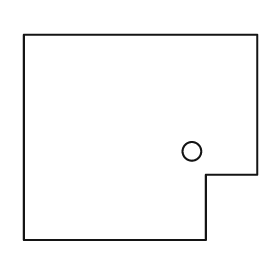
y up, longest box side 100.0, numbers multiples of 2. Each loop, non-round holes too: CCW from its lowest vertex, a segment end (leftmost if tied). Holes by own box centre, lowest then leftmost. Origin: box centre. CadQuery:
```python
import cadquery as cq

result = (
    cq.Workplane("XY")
    .moveTo(-50.0, -44.0)
    .lineTo(28.0, -44.0)
    .lineTo(28.0, -16.0)
    .lineTo(50.0, -16.0)
    .lineTo(50.0, 44.0)
    .lineTo(-50.0, 44.0)
    .close()
    .moveTo(22.0, -6.0)
    .circle(4.0)
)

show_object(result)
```